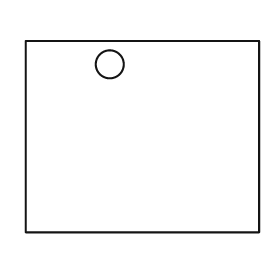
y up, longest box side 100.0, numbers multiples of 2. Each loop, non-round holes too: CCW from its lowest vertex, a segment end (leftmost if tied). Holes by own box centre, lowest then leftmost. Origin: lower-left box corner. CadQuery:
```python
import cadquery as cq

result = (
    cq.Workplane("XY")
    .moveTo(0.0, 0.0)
    .lineTo(100.0, 0.0)
    .lineTo(100.0, 82.0)
    .lineTo(0.0, 82.0)
    .close()
    .moveTo(36.0, 72.0)
    .circle(6.0)
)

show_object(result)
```